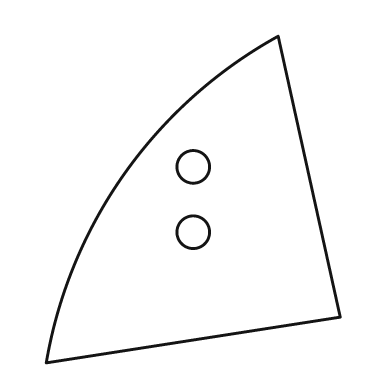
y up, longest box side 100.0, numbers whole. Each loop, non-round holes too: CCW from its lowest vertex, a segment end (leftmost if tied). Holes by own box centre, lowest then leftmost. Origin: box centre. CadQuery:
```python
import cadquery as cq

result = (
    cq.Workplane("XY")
    .moveTo(-45.0, -50.0)
    .lineTo(45.0, -36.0)
    .lineTo(26.0, 50.0)
    .threePointArc((-21.0, 8.0), (-45.0, -50.0))
    .close()
    .moveTo(0.0, -10.0)
    .circle(5.0)
    .moveTo(0.0, 10.0)
    .circle(5.0)
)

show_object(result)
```